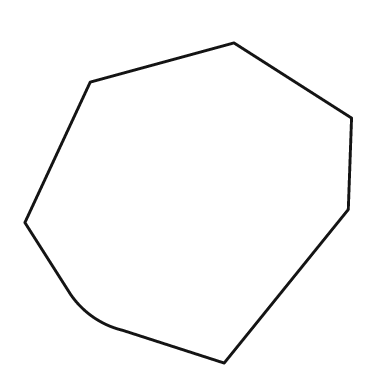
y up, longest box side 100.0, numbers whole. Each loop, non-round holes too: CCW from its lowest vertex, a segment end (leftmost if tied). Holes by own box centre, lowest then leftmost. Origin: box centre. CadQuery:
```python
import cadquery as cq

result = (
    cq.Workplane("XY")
    .moveTo(11.0, -49.0)
    .lineTo(49.0, -2.0)
    .lineTo(50.0, 26.0)
    .lineTo(14.0, 49.0)
    .lineTo(-30.0, 37.0)
    .lineTo(-50.0, -6.0)
    .lineTo(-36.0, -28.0)
    .threePointArc((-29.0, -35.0), (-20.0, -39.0))
    .close()
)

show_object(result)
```